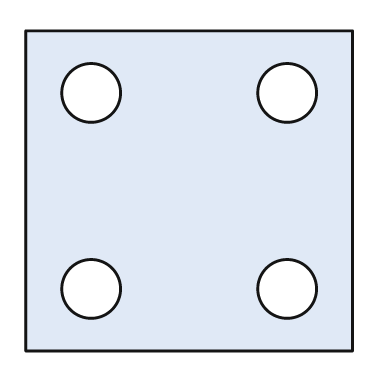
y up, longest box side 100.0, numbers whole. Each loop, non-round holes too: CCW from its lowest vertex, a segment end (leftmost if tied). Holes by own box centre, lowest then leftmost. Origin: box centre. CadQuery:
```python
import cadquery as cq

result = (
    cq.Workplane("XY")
    .moveTo(-50.0, -49.0)
    .lineTo(50.0, -49.0)
    .lineTo(50.0, 49.0)
    .lineTo(-50.0, 49.0)
    .close()
    .moveTo(-30.0, -30.0)
    .circle(9.0)
    .moveTo(30.0, -30.0)
    .circle(9.0)
    .moveTo(-30.0, 30.0)
    .circle(9.0)
    .moveTo(30.0, 30.0)
    .circle(9.0)
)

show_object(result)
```